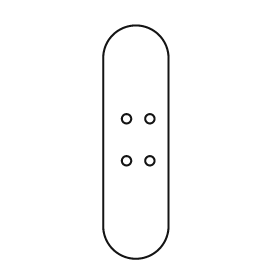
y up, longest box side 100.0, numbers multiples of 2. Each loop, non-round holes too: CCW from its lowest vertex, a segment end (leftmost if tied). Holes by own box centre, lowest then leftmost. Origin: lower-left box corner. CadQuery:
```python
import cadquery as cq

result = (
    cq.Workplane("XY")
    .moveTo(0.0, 14.0)
    .threePointArc((14.0, 0.0), (28.0, 14.0))
    .lineTo(28.0, 86.0)
    .threePointArc((14.0, 100.0), (0.0, 86.0))
    .close()
    .moveTo(10.0, 42.0)
    .circle(2.0)
    .moveTo(20.0, 42.0)
    .circle(2.0)
    .moveTo(10.0, 60.0)
    .circle(2.0)
    .moveTo(20.0, 60.0)
    .circle(2.0)
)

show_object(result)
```